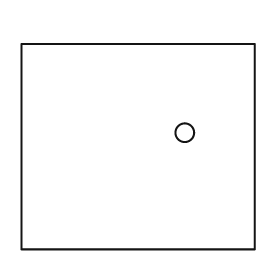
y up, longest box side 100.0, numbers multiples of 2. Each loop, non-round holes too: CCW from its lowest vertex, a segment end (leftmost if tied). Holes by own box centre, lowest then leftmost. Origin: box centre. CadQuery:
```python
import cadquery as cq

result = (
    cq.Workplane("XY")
    .moveTo(-50.0, -44.0)
    .lineTo(50.0, -44.0)
    .lineTo(50.0, 44.0)
    .lineTo(-50.0, 44.0)
    .close()
    .moveTo(20.0, 6.0)
    .circle(4.0)
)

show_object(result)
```